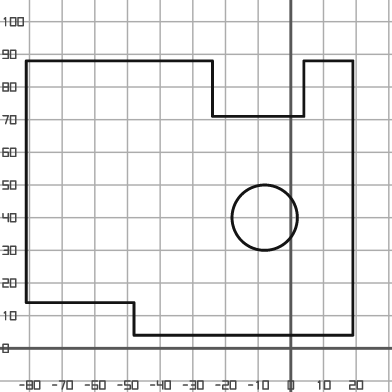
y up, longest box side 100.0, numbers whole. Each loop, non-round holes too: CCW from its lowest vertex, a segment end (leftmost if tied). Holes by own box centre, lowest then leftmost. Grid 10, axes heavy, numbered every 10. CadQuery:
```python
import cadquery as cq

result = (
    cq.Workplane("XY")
    .moveTo(-48.0, 4.0)
    .lineTo(19.0, 4.0)
    .lineTo(19.0, 88.0)
    .lineTo(4.0, 88.0)
    .lineTo(4.0, 71.0)
    .lineTo(-24.0, 71.0)
    .lineTo(-24.0, 88.0)
    .lineTo(-81.0, 88.0)
    .lineTo(-81.0, 14.0)
    .lineTo(-48.0, 14.0)
    .close()
    .moveTo(-8.0, 40.0)
    .circle(10.0)
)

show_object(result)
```